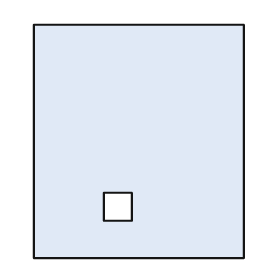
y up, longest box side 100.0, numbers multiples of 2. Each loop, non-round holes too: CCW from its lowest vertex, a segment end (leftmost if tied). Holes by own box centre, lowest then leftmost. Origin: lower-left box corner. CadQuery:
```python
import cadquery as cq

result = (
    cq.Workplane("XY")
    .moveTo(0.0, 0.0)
    .lineTo(90.0, 0.0)
    .lineTo(90.0, 100.0)
    .lineTo(0.0, 100.0)
    .close()
    .moveTo(30.0, 16.0)
    .lineTo(42.0, 16.0)
    .lineTo(42.0, 28.0)
    .lineTo(30.0, 28.0)
    .close()
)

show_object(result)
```